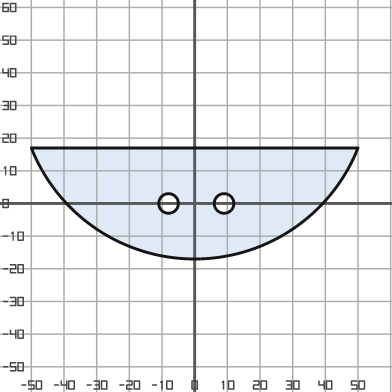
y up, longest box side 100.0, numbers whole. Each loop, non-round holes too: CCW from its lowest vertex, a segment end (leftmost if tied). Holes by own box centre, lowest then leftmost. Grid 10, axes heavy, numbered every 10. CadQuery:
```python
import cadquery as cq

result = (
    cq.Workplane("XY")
    .moveTo(-50.0, 17.0)
    .threePointArc((0.0, -17.0), (50.0, 17.0))
    .close()
    .moveTo(-8.0, 0.0)
    .circle(3.0)
    .moveTo(9.0, 0.0)
    .circle(3.0)
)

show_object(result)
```